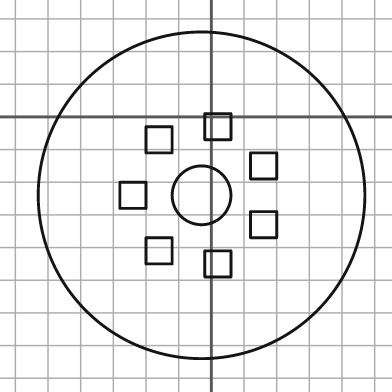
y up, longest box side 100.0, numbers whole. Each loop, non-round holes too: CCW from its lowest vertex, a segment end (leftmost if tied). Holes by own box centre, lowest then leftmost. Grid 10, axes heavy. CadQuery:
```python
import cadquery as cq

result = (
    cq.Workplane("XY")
    .moveTo(-3.0, -24.0)
    .circle(50.0)
    .moveTo(-2.0, -49.0)
    .lineTo(6.0, -49.0)
    .lineTo(6.0, -41.0)
    .lineTo(-2.0, -41.0)
    .close()
    .moveTo(-20.0, -45.0)
    .lineTo(-12.0, -45.0)
    .lineTo(-12.0, -37.0)
    .lineTo(-20.0, -37.0)
    .close()
    .moveTo(12.0, -37.0)
    .lineTo(20.0, -37.0)
    .lineTo(20.0, -29.0)
    .lineTo(12.0, -29.0)
    .close()
    .moveTo(-28.0, -28.0)
    .lineTo(-20.0, -28.0)
    .lineTo(-20.0, -20.0)
    .lineTo(-28.0, -20.0)
    .close()
    .moveTo(-3.0, -24.0)
    .circle(9.0)
    .moveTo(12.0, -19.0)
    .lineTo(20.0, -19.0)
    .lineTo(20.0, -11.0)
    .lineTo(12.0, -11.0)
    .close()
    .moveTo(-20.0, -11.0)
    .lineTo(-12.0, -11.0)
    .lineTo(-12.0, -3.0)
    .lineTo(-20.0, -3.0)
    .close()
    .moveTo(-2.0, -7.0)
    .lineTo(6.0, -7.0)
    .lineTo(6.0, 1.0)
    .lineTo(-2.0, 1.0)
    .close()
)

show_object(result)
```